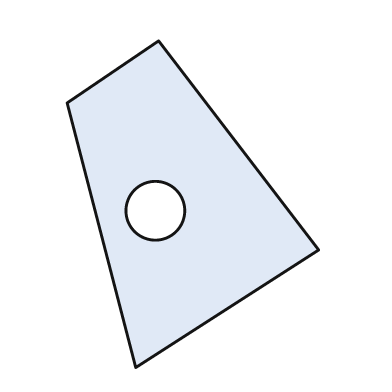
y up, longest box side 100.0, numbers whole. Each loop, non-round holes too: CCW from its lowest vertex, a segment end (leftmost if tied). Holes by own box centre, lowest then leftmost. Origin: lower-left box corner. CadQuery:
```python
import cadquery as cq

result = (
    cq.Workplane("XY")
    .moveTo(21.0, 0.0)
    .lineTo(77.0, 36.0)
    .lineTo(28.0, 100.0)
    .lineTo(0.0, 81.0)
    .close()
    .moveTo(27.0, 48.0)
    .circle(9.0)
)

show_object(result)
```